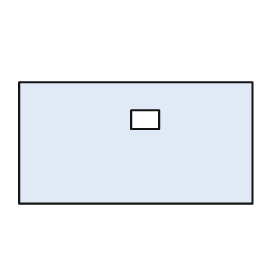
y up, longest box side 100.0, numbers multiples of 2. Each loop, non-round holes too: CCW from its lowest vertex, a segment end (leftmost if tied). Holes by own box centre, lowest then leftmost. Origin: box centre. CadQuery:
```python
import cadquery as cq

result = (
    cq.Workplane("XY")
    .moveTo(-50.0, -26.0)
    .lineTo(50.0, -26.0)
    .lineTo(50.0, 26.0)
    .lineTo(-50.0, 26.0)
    .close()
    .moveTo(-2.0, 6.0)
    .lineTo(10.0, 6.0)
    .lineTo(10.0, 14.0)
    .lineTo(-2.0, 14.0)
    .close()
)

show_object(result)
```